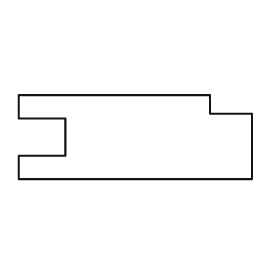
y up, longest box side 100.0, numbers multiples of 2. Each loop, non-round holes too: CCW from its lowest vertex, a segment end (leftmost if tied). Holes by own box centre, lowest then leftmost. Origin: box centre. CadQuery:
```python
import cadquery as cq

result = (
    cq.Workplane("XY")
    .moveTo(-50.0, -18.0)
    .lineTo(50.0, -18.0)
    .lineTo(50.0, 10.0)
    .lineTo(32.0, 10.0)
    .lineTo(32.0, 18.0)
    .lineTo(-50.0, 18.0)
    .lineTo(-50.0, 8.0)
    .lineTo(-30.0, 8.0)
    .lineTo(-30.0, -8.0)
    .lineTo(-50.0, -8.0)
    .close()
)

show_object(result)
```